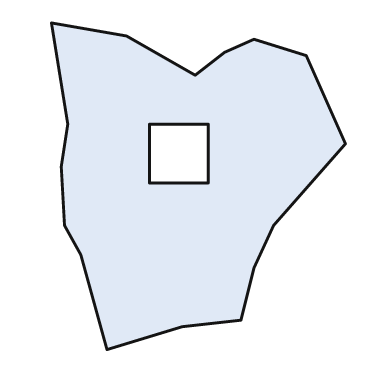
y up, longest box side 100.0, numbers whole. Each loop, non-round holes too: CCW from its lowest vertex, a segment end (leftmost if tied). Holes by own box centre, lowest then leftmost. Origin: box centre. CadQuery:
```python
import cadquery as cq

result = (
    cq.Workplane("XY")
    .moveTo(-28.0, -50.0)
    .lineTo(-5.0, -43.0)
    .lineTo(13.0, -41.0)
    .lineTo(17.0, -25.0)
    .lineTo(23.0, -12.0)
    .lineTo(45.0, 13.0)
    .lineTo(33.0, 40.0)
    .lineTo(17.0, 45.0)
    .lineTo(8.0, 41.0)
    .lineTo(-1.0, 34.0)
    .lineTo(-22.0, 46.0)
    .lineTo(-45.0, 50.0)
    .lineTo(-40.0, 19.0)
    .lineTo(-42.0, 6.0)
    .lineTo(-41.0, -12.0)
    .lineTo(-36.0, -21.0)
    .close()
    .moveTo(-15.0, 1.0)
    .lineTo(3.0, 1.0)
    .lineTo(3.0, 19.0)
    .lineTo(-15.0, 19.0)
    .close()
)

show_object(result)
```